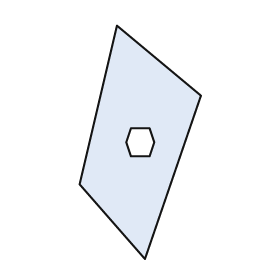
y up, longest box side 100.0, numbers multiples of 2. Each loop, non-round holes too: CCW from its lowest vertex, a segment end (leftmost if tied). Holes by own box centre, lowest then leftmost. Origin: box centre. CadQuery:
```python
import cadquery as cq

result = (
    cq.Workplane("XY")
    .moveTo(2.0, -50.0)
    .lineTo(26.0, 20.0)
    .lineTo(-10.0, 50.0)
    .lineTo(-26.0, -18.0)
    .close()
    .moveTo(-4.0, -6.0)
    .lineTo(4.0, -6.0)
    .lineTo(6.0, 0.0)
    .lineTo(4.0, 6.0)
    .lineTo(-4.0, 6.0)
    .lineTo(-6.0, 0.0)
    .close()
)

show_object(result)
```